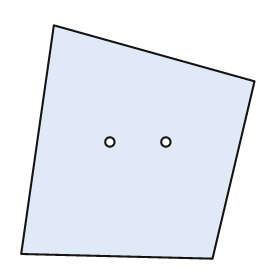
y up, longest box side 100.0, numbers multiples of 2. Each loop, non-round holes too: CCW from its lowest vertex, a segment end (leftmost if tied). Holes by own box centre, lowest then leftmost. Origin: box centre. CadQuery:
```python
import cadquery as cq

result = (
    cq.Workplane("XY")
    .moveTo(32.0, -50.0)
    .lineTo(50.0, 26.0)
    .lineTo(-36.0, 50.0)
    .lineTo(-50.0, -48.0)
    .close()
    .moveTo(-12.0, 0.0)
    .circle(2.0)
    .moveTo(12.0, 0.0)
    .circle(2.0)
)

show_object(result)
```